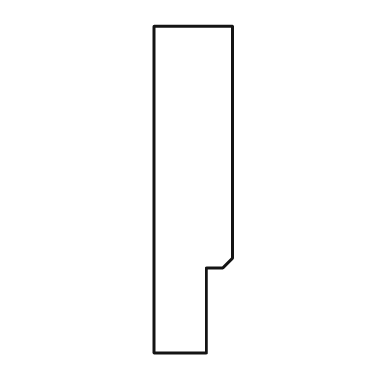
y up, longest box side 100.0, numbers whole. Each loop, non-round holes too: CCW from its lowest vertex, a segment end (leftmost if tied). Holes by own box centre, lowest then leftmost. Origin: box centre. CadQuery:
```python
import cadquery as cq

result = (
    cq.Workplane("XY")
    .moveTo(-12.0, -50.0)
    .lineTo(4.0, -50.0)
    .lineTo(4.0, -24.0)
    .lineTo(9.0, -24.0)
    .lineTo(12.0, -21.0)
    .lineTo(12.0, 50.0)
    .lineTo(-12.0, 50.0)
    .close()
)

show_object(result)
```